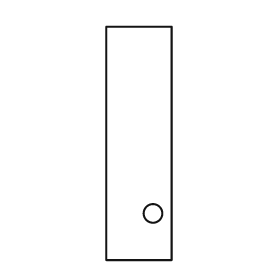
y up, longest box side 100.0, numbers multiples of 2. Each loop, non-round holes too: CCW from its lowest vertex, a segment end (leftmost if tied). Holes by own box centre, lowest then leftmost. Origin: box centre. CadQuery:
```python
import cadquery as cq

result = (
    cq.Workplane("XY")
    .moveTo(-14.0, -50.0)
    .lineTo(14.0, -50.0)
    .lineTo(14.0, 50.0)
    .lineTo(-14.0, 50.0)
    .close()
    .moveTo(6.0, -30.0)
    .circle(4.0)
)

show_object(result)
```